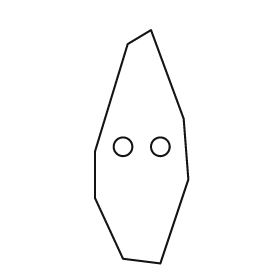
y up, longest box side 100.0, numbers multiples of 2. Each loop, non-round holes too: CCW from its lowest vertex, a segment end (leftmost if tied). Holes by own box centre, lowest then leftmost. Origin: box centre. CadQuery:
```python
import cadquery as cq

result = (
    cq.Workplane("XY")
    .moveTo(8.0, -50.0)
    .lineTo(20.0, -14.0)
    .lineTo(18.0, 12.0)
    .lineTo(4.0, 50.0)
    .lineTo(-6.0, 44.0)
    .lineTo(-20.0, -2.0)
    .lineTo(-20.0, -22.0)
    .lineTo(-8.0, -48.0)
    .close()
    .moveTo(-8.0, 0.0)
    .circle(4.0)
    .moveTo(8.0, 0.0)
    .circle(4.0)
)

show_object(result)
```